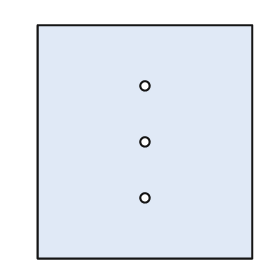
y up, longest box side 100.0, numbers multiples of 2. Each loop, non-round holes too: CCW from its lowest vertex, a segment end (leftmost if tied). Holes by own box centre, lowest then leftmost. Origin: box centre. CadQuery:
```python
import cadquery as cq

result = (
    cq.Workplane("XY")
    .moveTo(-46.0, -50.0)
    .lineTo(46.0, -50.0)
    .lineTo(46.0, 50.0)
    .lineTo(-46.0, 50.0)
    .close()
    .moveTo(0.0, -24.0)
    .circle(2.0)
    .moveTo(0.0, 0.0)
    .circle(2.0)
    .moveTo(0.0, 24.0)
    .circle(2.0)
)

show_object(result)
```